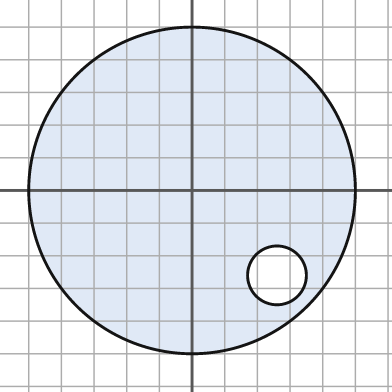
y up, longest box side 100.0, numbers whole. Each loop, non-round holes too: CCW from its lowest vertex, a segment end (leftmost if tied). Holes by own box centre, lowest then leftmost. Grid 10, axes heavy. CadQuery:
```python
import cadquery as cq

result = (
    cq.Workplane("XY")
    .moveTo(0.0, 0.0)
    .circle(50.0)
    .moveTo(26.0, -26.0)
    .circle(9.0)
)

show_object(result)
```